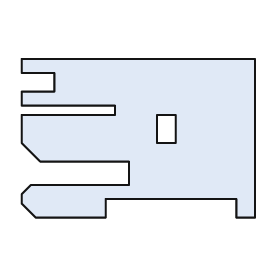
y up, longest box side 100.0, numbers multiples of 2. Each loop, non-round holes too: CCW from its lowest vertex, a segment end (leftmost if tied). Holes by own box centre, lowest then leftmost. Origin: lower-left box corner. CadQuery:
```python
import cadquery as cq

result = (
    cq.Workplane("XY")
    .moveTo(6.0, 0.0)
    .lineTo(36.0, 0.0)
    .lineTo(36.0, 8.0)
    .lineTo(92.0, 8.0)
    .lineTo(92.0, 0.0)
    .lineTo(100.0, 0.0)
    .lineTo(100.0, 68.0)
    .lineTo(0.0, 68.0)
    .lineTo(0.0, 62.0)
    .lineTo(14.0, 62.0)
    .lineTo(14.0, 54.0)
    .lineTo(0.0, 54.0)
    .lineTo(0.0, 48.0)
    .lineTo(40.0, 48.0)
    .lineTo(40.0, 44.0)
    .lineTo(0.0, 44.0)
    .lineTo(0.0, 32.0)
    .lineTo(8.0, 24.0)
    .lineTo(46.0, 24.0)
    .lineTo(46.0, 14.0)
    .lineTo(4.0, 14.0)
    .lineTo(0.0, 10.0)
    .lineTo(0.0, 6.0)
    .close()
    .moveTo(58.0, 32.0)
    .lineTo(66.0, 32.0)
    .lineTo(66.0, 44.0)
    .lineTo(58.0, 44.0)
    .close()
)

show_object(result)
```